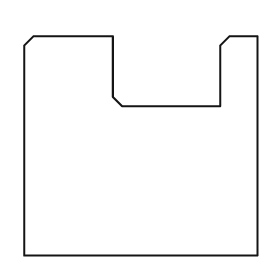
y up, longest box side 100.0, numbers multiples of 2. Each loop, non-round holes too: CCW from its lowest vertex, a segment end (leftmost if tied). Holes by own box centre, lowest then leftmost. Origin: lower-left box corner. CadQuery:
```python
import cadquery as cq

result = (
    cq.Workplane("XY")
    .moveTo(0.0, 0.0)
    .lineTo(100.0, 0.0)
    .lineTo(100.0, 94.0)
    .lineTo(88.0, 94.0)
    .lineTo(84.0, 90.0)
    .lineTo(84.0, 64.0)
    .lineTo(42.0, 64.0)
    .lineTo(38.0, 68.0)
    .lineTo(38.0, 94.0)
    .lineTo(4.0, 94.0)
    .lineTo(0.0, 90.0)
    .close()
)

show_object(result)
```